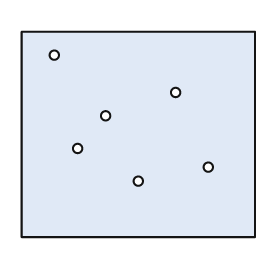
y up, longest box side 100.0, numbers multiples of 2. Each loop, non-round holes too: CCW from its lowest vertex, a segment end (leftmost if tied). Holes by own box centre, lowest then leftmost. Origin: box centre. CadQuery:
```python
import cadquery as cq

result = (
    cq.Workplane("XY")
    .moveTo(-50.0, -44.0)
    .lineTo(50.0, -44.0)
    .lineTo(50.0, 44.0)
    .lineTo(-50.0, 44.0)
    .close()
    .moveTo(0.0, -20.0)
    .circle(2.0)
    .moveTo(30.0, -14.0)
    .circle(2.0)
    .moveTo(-26.0, -6.0)
    .circle(2.0)
    .moveTo(-14.0, 8.0)
    .circle(2.0)
    .moveTo(16.0, 18.0)
    .circle(2.0)
    .moveTo(-36.0, 34.0)
    .circle(2.0)
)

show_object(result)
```